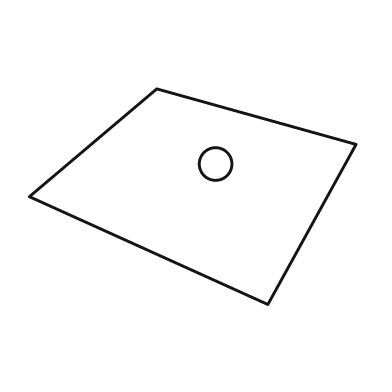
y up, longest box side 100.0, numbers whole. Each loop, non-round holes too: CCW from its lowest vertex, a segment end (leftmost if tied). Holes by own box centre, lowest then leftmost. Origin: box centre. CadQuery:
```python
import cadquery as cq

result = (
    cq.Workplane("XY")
    .moveTo(23.0, -33.0)
    .lineTo(50.0, 16.0)
    .lineTo(-11.0, 33.0)
    .lineTo(-50.0, 0.0)
    .close()
    .moveTo(7.0, 10.0)
    .circle(5.0)
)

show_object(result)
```